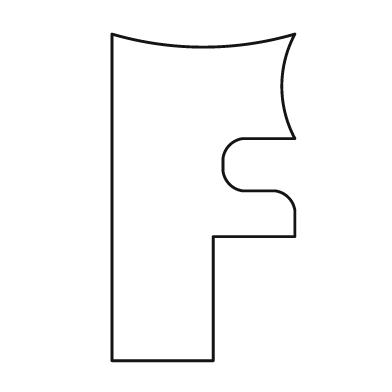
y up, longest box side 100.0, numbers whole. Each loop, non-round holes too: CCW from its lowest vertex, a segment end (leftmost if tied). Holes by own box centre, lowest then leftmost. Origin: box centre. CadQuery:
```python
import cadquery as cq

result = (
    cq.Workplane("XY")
    .moveTo(-28.0, -50.0)
    .lineTo(3.0, -50.0)
    .lineTo(3.0, -12.0)
    .lineTo(28.0, -12.0)
    .lineTo(28.0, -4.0)
    .threePointArc((26.0, 0.0), (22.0, 2.0))
    .lineTo(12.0, 2.0)
    .threePointArc((8.0, 4.0), (6.0, 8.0))
    .lineTo(6.0, 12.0)
    .threePointArc((8.0, 16.0), (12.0, 18.0))
    .lineTo(28.0, 18.0)
    .threePointArc((24.0, 34.0), (28.0, 50.0))
    .threePointArc((0.0, 46.0), (-28.0, 50.0))
    .close()
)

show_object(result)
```